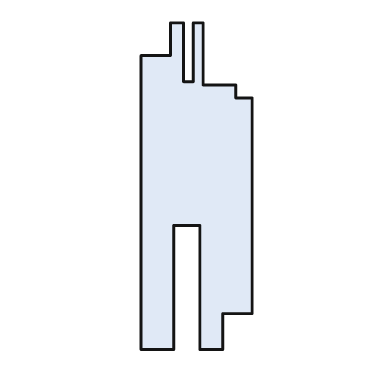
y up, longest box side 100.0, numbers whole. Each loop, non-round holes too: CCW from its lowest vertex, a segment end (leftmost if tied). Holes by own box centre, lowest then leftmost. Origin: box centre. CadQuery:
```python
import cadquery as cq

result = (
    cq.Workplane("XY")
    .moveTo(-17.0, -50.0)
    .lineTo(-7.0, -50.0)
    .lineTo(-7.0, -12.0)
    .lineTo(1.0, -12.0)
    .lineTo(1.0, -50.0)
    .lineTo(8.0, -50.0)
    .lineTo(8.0, -39.0)
    .lineTo(17.0, -39.0)
    .lineTo(17.0, 27.0)
    .lineTo(12.0, 27.0)
    .lineTo(12.0, 31.0)
    .lineTo(2.0, 31.0)
    .lineTo(2.0, 50.0)
    .lineTo(-1.0, 50.0)
    .lineTo(-1.0, 32.0)
    .lineTo(-4.0, 32.0)
    .lineTo(-4.0, 50.0)
    .lineTo(-8.0, 50.0)
    .lineTo(-8.0, 40.0)
    .lineTo(-17.0, 40.0)
    .close()
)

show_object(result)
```